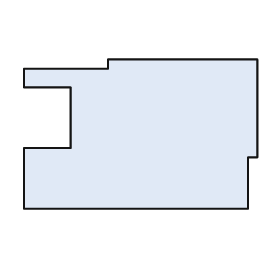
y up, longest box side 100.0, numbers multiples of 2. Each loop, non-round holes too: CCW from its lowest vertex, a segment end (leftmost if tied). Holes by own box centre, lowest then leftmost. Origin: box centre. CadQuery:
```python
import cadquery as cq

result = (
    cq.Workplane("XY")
    .moveTo(-50.0, -32.0)
    .lineTo(46.0, -32.0)
    .lineTo(46.0, -10.0)
    .lineTo(50.0, -10.0)
    .lineTo(50.0, 32.0)
    .lineTo(-14.0, 32.0)
    .lineTo(-14.0, 28.0)
    .lineTo(-50.0, 28.0)
    .lineTo(-50.0, 20.0)
    .lineTo(-30.0, 20.0)
    .lineTo(-30.0, -6.0)
    .lineTo(-50.0, -6.0)
    .close()
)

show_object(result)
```